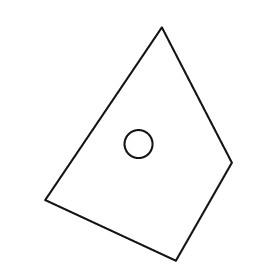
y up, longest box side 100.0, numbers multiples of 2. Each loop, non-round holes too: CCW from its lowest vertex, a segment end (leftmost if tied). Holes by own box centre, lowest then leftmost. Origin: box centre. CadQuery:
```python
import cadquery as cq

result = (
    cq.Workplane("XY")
    .moveTo(16.0, -50.0)
    .lineTo(40.0, -8.0)
    .lineTo(10.0, 50.0)
    .lineTo(-40.0, -24.0)
    .close()
    .moveTo(0.0, 0.0)
    .circle(6.0)
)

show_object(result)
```